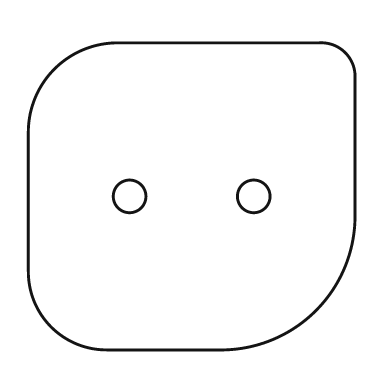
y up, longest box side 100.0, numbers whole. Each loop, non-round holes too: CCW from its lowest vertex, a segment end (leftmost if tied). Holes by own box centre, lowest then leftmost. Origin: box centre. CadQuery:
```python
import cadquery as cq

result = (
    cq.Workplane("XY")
    .moveTo(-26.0, -47.0)
    .lineTo(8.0, -47.0)
    .threePointArc((38.0, -35.0), (50.0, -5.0))
    .lineTo(50.0, 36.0)
    .threePointArc((47.0, 44.0), (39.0, 47.0))
    .lineTo(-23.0, 47.0)
    .threePointArc((-42.0, 39.0), (-50.0, 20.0))
    .lineTo(-50.0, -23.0)
    .threePointArc((-43.0, -40.0), (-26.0, -47.0))
    .close()
    .moveTo(-19.0, 0.0)
    .circle(5.0)
    .moveTo(19.0, 0.0)
    .circle(5.0)
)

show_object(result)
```